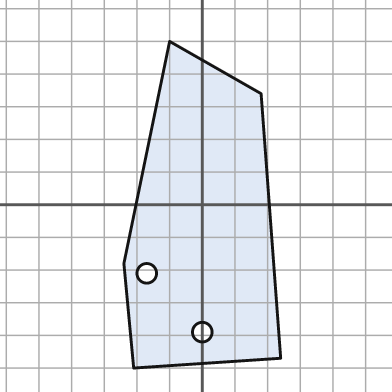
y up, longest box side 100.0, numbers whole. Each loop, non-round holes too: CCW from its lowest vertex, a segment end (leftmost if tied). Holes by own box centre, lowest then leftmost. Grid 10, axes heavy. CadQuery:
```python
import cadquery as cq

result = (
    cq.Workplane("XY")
    .moveTo(-21.0, -50.0)
    .lineTo(24.0, -47.0)
    .lineTo(18.0, 34.0)
    .lineTo(-10.0, 50.0)
    .lineTo(-24.0, -18.0)
    .close()
    .moveTo(0.0, -39.0)
    .circle(3.0)
    .moveTo(-17.0, -21.0)
    .circle(3.0)
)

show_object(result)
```